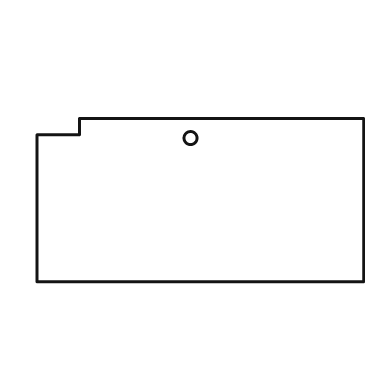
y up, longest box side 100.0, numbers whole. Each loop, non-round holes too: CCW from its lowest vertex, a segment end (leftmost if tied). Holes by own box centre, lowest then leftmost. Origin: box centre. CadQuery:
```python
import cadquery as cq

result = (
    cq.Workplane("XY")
    .moveTo(-50.0, -25.0)
    .lineTo(50.0, -25.0)
    .lineTo(50.0, 25.0)
    .lineTo(-37.0, 25.0)
    .lineTo(-37.0, 20.0)
    .lineTo(-50.0, 20.0)
    .close()
    .moveTo(-3.0, 19.0)
    .circle(2.0)
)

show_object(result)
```